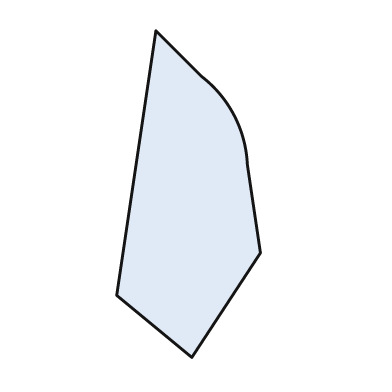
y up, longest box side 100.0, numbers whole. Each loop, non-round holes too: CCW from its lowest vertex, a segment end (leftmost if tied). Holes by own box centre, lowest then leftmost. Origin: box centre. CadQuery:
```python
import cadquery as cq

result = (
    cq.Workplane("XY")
    .moveTo(1.0, -50.0)
    .lineTo(22.0, -18.0)
    .lineTo(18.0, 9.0)
    .threePointArc((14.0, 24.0), (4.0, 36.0))
    .lineTo(-10.0, 50.0)
    .lineTo(-22.0, -31.0)
    .close()
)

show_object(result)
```